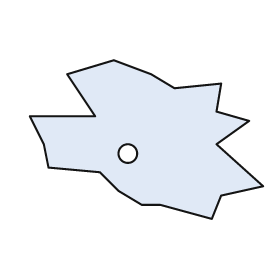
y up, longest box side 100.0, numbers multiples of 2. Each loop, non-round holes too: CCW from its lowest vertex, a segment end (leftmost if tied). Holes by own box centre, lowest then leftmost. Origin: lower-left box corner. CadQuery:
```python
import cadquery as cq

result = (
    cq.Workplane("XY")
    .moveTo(78.0, 0.0)
    .lineTo(82.0, 10.0)
    .lineTo(100.0, 14.0)
    .lineTo(80.0, 32.0)
    .lineTo(94.0, 42.0)
    .lineTo(80.0, 46.0)
    .lineTo(82.0, 58.0)
    .lineTo(62.0, 56.0)
    .lineTo(52.0, 62.0)
    .lineTo(36.0, 68.0)
    .lineTo(16.0, 62.0)
    .lineTo(28.0, 44.0)
    .lineTo(0.0, 44.0)
    .lineTo(6.0, 32.0)
    .lineTo(8.0, 22.0)
    .lineTo(30.0, 20.0)
    .lineTo(38.0, 12.0)
    .lineTo(48.0, 6.0)
    .lineTo(56.0, 6.0)
    .close()
    .moveTo(42.0, 28.0)
    .circle(4.0)
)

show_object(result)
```